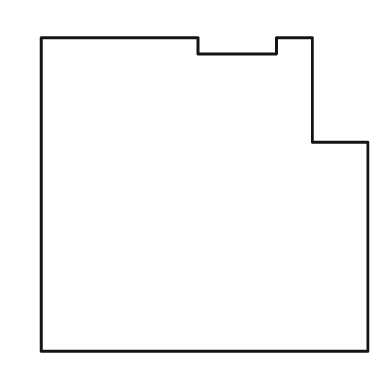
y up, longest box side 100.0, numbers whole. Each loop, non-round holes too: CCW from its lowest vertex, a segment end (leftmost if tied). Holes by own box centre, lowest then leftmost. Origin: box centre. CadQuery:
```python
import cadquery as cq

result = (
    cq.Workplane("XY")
    .moveTo(-50.0, -48.0)
    .lineTo(50.0, -48.0)
    .lineTo(50.0, 16.0)
    .lineTo(33.0, 16.0)
    .lineTo(33.0, 48.0)
    .lineTo(22.0, 48.0)
    .lineTo(22.0, 43.0)
    .lineTo(-2.0, 43.0)
    .lineTo(-2.0, 48.0)
    .lineTo(-50.0, 48.0)
    .close()
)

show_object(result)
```